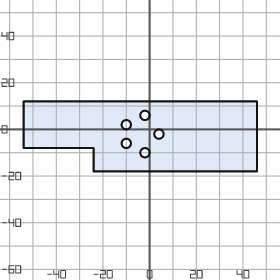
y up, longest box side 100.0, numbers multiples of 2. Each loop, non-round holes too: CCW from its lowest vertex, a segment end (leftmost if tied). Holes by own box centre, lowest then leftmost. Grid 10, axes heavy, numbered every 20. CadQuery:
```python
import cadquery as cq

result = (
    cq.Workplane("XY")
    .moveTo(-24.0, -18.0)
    .lineTo(46.0, -18.0)
    .lineTo(46.0, 12.0)
    .lineTo(-54.0, 12.0)
    .lineTo(-54.0, -8.0)
    .lineTo(-24.0, -8.0)
    .close()
    .moveTo(-2.0, -10.0)
    .circle(2.0)
    .moveTo(-10.0, -6.0)
    .circle(2.0)
    .moveTo(4.0, -2.0)
    .circle(2.0)
    .moveTo(-10.0, 2.0)
    .circle(2.0)
    .moveTo(-2.0, 6.0)
    .circle(2.0)
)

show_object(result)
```